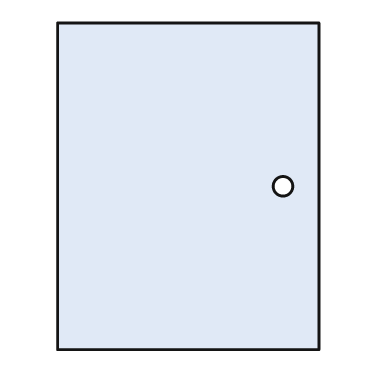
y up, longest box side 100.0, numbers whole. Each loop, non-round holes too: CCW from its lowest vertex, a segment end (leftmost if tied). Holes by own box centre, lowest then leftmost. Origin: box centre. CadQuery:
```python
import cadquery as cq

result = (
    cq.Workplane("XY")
    .moveTo(-40.0, -50.0)
    .lineTo(40.0, -50.0)
    .lineTo(40.0, 50.0)
    .lineTo(-40.0, 50.0)
    .close()
    .moveTo(29.0, 0.0)
    .circle(3.0)
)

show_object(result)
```